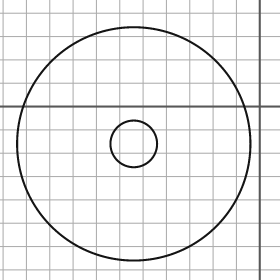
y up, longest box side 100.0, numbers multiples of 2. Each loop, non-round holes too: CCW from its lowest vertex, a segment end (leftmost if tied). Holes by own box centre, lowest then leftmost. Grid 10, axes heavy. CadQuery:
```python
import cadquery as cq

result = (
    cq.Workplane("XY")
    .moveTo(-54.0, -16.0)
    .circle(50.0)
    .moveTo(-54.0, -16.0)
    .circle(10.0)
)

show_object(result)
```